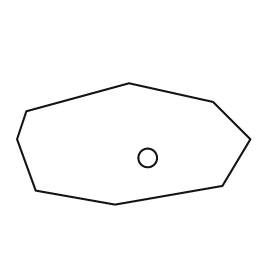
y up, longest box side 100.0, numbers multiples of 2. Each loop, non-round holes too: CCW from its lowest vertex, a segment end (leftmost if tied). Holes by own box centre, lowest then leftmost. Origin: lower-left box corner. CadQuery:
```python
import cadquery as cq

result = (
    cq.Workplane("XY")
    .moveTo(42.0, 0.0)
    .lineTo(88.0, 8.0)
    .lineTo(100.0, 28.0)
    .lineTo(84.0, 44.0)
    .lineTo(48.0, 52.0)
    .lineTo(4.0, 40.0)
    .lineTo(0.0, 28.0)
    .lineTo(8.0, 6.0)
    .close()
    .moveTo(56.0, 20.0)
    .circle(4.0)
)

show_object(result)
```